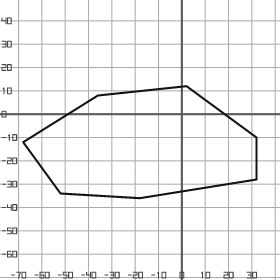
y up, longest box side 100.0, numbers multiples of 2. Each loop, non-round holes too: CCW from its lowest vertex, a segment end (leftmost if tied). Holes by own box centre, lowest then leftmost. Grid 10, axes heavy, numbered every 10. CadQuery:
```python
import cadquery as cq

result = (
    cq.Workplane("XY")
    .moveTo(-18.0, -36.0)
    .lineTo(32.0, -28.0)
    .lineTo(32.0, -10.0)
    .lineTo(2.0, 12.0)
    .lineTo(-36.0, 8.0)
    .lineTo(-68.0, -12.0)
    .lineTo(-52.0, -34.0)
    .close()
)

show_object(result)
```